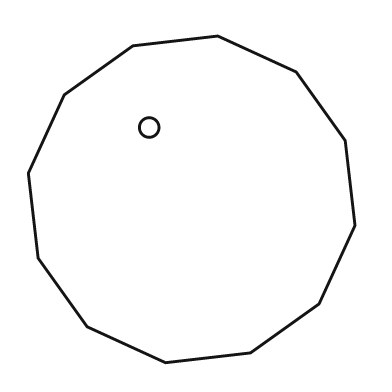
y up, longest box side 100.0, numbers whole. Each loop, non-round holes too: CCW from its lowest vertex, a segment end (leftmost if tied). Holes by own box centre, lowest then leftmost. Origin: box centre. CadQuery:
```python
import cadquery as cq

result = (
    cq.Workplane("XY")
    .moveTo(-8.0, -50.0)
    .lineTo(18.0, -47.0)
    .lineTo(39.0, -32.0)
    .lineTo(50.0, -8.0)
    .lineTo(47.0, 18.0)
    .lineTo(32.0, 39.0)
    .lineTo(8.0, 50.0)
    .lineTo(-18.0, 47.0)
    .lineTo(-39.0, 32.0)
    .lineTo(-50.0, 8.0)
    .lineTo(-47.0, -18.0)
    .lineTo(-32.0, -39.0)
    .close()
    .moveTo(-13.0, 22.0)
    .circle(3.0)
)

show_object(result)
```